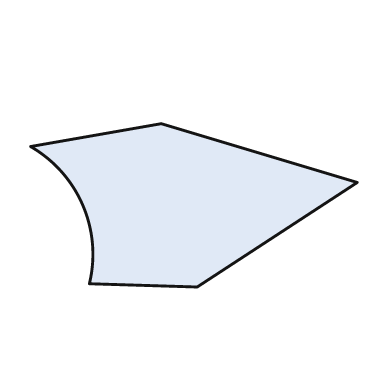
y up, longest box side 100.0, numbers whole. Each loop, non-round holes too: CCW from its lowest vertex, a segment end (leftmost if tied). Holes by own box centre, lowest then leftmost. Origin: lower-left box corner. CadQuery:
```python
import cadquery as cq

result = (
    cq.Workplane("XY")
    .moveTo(51.0, 0.0)
    .lineTo(100.0, 32.0)
    .lineTo(40.0, 50.0)
    .lineTo(0.0, 43.0)
    .threePointArc((16.0, 25.0), (18.0, 1.0))
    .close()
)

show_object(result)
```